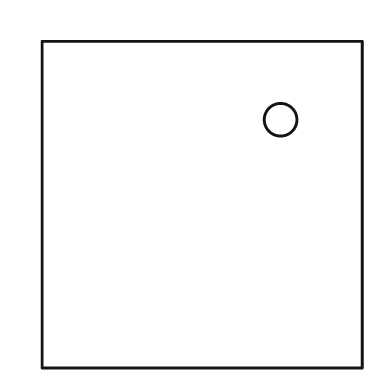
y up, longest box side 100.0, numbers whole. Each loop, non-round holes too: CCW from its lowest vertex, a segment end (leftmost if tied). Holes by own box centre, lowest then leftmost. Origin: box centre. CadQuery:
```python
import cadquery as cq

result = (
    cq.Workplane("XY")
    .moveTo(-49.0, -50.0)
    .lineTo(49.0, -50.0)
    .lineTo(49.0, 50.0)
    .lineTo(-49.0, 50.0)
    .close()
    .moveTo(24.0, 26.0)
    .circle(5.0)
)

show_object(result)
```